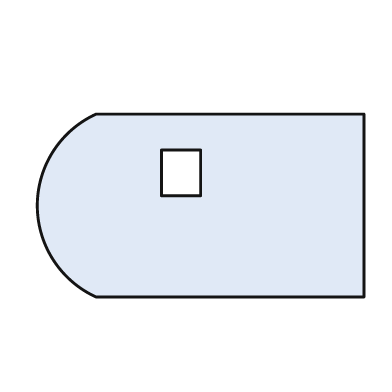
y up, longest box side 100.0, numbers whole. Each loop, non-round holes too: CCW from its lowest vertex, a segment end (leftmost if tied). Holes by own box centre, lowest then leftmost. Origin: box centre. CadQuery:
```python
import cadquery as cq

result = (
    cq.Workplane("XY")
    .moveTo(-32.0, -28.0)
    .lineTo(50.0, -28.0)
    .lineTo(50.0, 28.0)
    .lineTo(-32.0, 28.0)
    .threePointArc((-50.0, 0.0), (-32.0, -28.0))
    .close()
    .moveTo(-12.0, 3.0)
    .lineTo(0.0, 3.0)
    .lineTo(0.0, 17.0)
    .lineTo(-12.0, 17.0)
    .close()
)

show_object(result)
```